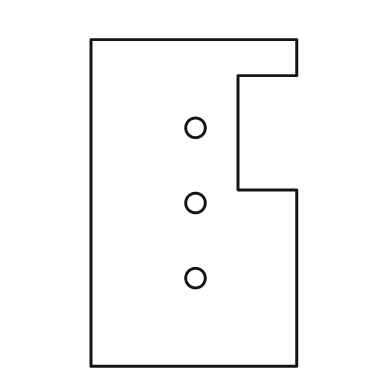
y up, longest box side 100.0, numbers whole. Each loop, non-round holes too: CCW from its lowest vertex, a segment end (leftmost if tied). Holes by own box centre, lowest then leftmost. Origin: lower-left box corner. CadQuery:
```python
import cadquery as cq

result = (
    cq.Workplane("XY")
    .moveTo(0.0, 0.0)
    .lineTo(63.0, 0.0)
    .lineTo(63.0, 54.0)
    .lineTo(45.0, 54.0)
    .lineTo(45.0, 89.0)
    .lineTo(63.0, 89.0)
    .lineTo(63.0, 100.0)
    .lineTo(0.0, 100.0)
    .close()
    .moveTo(32.0, 27.0)
    .circle(3.0)
    .moveTo(32.0, 50.0)
    .circle(3.0)
    .moveTo(32.0, 73.0)
    .circle(3.0)
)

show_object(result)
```